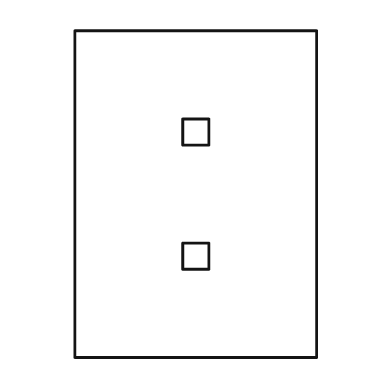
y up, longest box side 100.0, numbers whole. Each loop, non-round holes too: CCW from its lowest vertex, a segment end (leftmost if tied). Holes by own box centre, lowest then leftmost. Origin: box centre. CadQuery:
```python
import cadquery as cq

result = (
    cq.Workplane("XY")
    .moveTo(-37.0, -50.0)
    .lineTo(37.0, -50.0)
    .lineTo(37.0, 50.0)
    .lineTo(-37.0, 50.0)
    .close()
    .moveTo(-4.0, -23.0)
    .lineTo(4.0, -23.0)
    .lineTo(4.0, -15.0)
    .lineTo(-4.0, -15.0)
    .close()
    .moveTo(-4.0, 15.0)
    .lineTo(4.0, 15.0)
    .lineTo(4.0, 23.0)
    .lineTo(-4.0, 23.0)
    .close()
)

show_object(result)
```